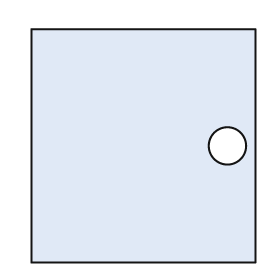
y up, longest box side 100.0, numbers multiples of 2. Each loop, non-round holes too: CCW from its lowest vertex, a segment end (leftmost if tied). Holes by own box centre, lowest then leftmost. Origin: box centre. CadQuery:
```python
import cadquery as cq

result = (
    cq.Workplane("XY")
    .moveTo(-48.0, -50.0)
    .lineTo(48.0, -50.0)
    .lineTo(48.0, 50.0)
    .lineTo(-48.0, 50.0)
    .close()
    .moveTo(36.0, 0.0)
    .circle(8.0)
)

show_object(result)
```